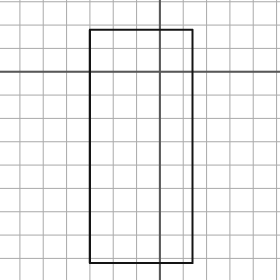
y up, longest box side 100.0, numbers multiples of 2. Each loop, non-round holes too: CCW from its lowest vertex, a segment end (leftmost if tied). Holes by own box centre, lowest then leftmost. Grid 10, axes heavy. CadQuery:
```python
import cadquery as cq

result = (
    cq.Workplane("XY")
    .moveTo(-30.0, -82.0)
    .lineTo(14.0, -82.0)
    .lineTo(14.0, 18.0)
    .lineTo(-30.0, 18.0)
    .close()
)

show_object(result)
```